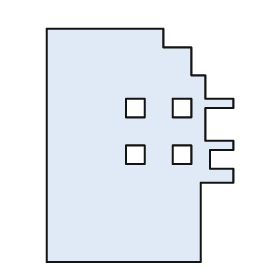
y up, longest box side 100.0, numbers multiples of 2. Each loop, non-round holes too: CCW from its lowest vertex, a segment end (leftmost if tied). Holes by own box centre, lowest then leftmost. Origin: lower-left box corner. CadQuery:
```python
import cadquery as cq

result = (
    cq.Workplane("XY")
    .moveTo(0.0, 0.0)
    .lineTo(66.0, 0.0)
    .lineTo(66.0, 34.0)
    .lineTo(80.0, 34.0)
    .lineTo(80.0, 40.0)
    .lineTo(70.0, 40.0)
    .lineTo(70.0, 48.0)
    .lineTo(80.0, 48.0)
    .lineTo(80.0, 52.0)
    .lineTo(68.0, 52.0)
    .lineTo(68.0, 66.0)
    .lineTo(80.0, 66.0)
    .lineTo(80.0, 70.0)
    .lineTo(68.0, 70.0)
    .lineTo(68.0, 80.0)
    .lineTo(62.0, 80.0)
    .lineTo(62.0, 92.0)
    .lineTo(50.0, 92.0)
    .lineTo(50.0, 100.0)
    .lineTo(0.0, 100.0)
    .close()
    .moveTo(34.0, 42.0)
    .lineTo(42.0, 42.0)
    .lineTo(42.0, 50.0)
    .lineTo(34.0, 50.0)
    .close()
    .moveTo(54.0, 42.0)
    .lineTo(62.0, 42.0)
    .lineTo(62.0, 50.0)
    .lineTo(54.0, 50.0)
    .close()
    .moveTo(34.0, 62.0)
    .lineTo(42.0, 62.0)
    .lineTo(42.0, 70.0)
    .lineTo(34.0, 70.0)
    .close()
    .moveTo(54.0, 62.0)
    .lineTo(62.0, 62.0)
    .lineTo(62.0, 70.0)
    .lineTo(54.0, 70.0)
    .close()
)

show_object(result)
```